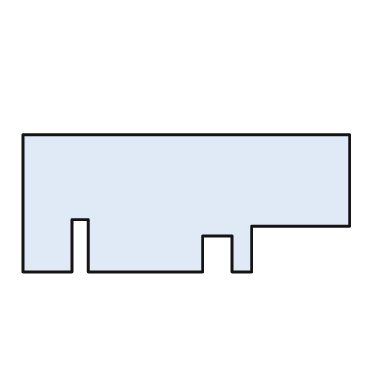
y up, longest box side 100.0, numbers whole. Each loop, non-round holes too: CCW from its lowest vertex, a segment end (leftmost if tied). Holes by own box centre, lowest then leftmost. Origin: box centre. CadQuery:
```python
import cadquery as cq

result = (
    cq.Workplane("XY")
    .moveTo(-50.0, -21.0)
    .lineTo(-35.0, -21.0)
    .lineTo(-35.0, -5.0)
    .lineTo(-30.0, -5.0)
    .lineTo(-30.0, -21.0)
    .lineTo(5.0, -21.0)
    .lineTo(5.0, -10.0)
    .lineTo(14.0, -10.0)
    .lineTo(14.0, -21.0)
    .lineTo(20.0, -21.0)
    .lineTo(20.0, -7.0)
    .lineTo(50.0, -7.0)
    .lineTo(50.0, 21.0)
    .lineTo(-50.0, 21.0)
    .close()
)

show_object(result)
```